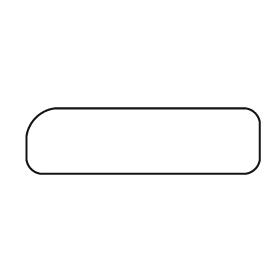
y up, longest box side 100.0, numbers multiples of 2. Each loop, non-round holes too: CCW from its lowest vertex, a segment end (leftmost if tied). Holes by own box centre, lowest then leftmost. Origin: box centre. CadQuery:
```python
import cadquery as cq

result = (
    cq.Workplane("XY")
    .moveTo(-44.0, -14.0)
    .lineTo(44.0, -14.0)
    .threePointArc((48.0, -12.0), (50.0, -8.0))
    .lineTo(50.0, 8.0)
    .threePointArc((48.0, 12.0), (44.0, 14.0))
    .lineTo(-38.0, 14.0)
    .threePointArc((-46.0, 10.0), (-50.0, 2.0))
    .lineTo(-50.0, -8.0)
    .threePointArc((-48.0, -12.0), (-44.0, -14.0))
    .close()
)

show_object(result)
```